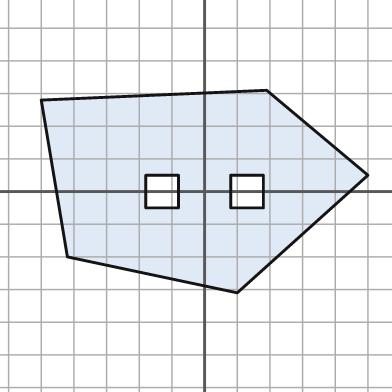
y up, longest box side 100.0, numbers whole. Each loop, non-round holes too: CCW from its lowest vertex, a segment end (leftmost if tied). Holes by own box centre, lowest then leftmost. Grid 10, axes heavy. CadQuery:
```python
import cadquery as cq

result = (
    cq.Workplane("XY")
    .moveTo(10.0, -31.0)
    .lineTo(50.0, 5.0)
    .lineTo(19.0, 31.0)
    .lineTo(-50.0, 28.0)
    .lineTo(-42.0, -20.0)
    .close()
    .moveTo(-18.0, -5.0)
    .lineTo(-8.0, -5.0)
    .lineTo(-8.0, 5.0)
    .lineTo(-18.0, 5.0)
    .close()
    .moveTo(8.0, -5.0)
    .lineTo(18.0, -5.0)
    .lineTo(18.0, 5.0)
    .lineTo(8.0, 5.0)
    .close()
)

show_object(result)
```